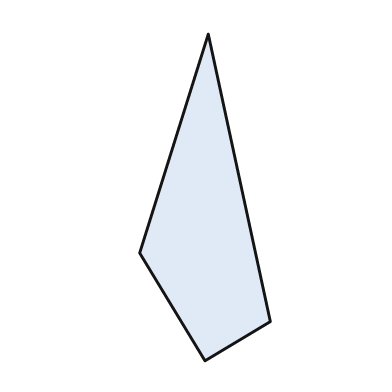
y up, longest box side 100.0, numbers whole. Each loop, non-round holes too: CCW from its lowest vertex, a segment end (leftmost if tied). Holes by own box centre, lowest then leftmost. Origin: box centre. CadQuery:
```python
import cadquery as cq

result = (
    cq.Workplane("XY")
    .moveTo(0.0, -50.0)
    .lineTo(20.0, -38.0)
    .lineTo(1.0, 50.0)
    .lineTo(-20.0, -17.0)
    .close()
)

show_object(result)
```